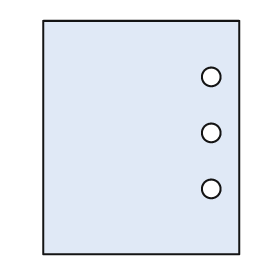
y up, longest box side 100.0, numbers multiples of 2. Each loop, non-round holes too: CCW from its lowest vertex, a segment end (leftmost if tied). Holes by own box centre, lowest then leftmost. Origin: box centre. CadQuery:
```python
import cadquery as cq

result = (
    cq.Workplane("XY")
    .moveTo(-42.0, -50.0)
    .lineTo(42.0, -50.0)
    .lineTo(42.0, 50.0)
    .lineTo(-42.0, 50.0)
    .close()
    .moveTo(30.0, -22.0)
    .circle(4.0)
    .moveTo(30.0, 2.0)
    .circle(4.0)
    .moveTo(30.0, 26.0)
    .circle(4.0)
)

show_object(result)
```